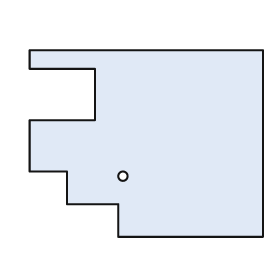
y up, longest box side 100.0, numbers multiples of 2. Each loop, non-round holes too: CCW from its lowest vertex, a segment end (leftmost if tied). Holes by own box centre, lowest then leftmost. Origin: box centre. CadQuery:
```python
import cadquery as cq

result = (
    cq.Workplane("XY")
    .moveTo(-12.0, -40.0)
    .lineTo(50.0, -40.0)
    .lineTo(50.0, 40.0)
    .lineTo(-50.0, 40.0)
    .lineTo(-50.0, 32.0)
    .lineTo(-22.0, 32.0)
    .lineTo(-22.0, 10.0)
    .lineTo(-50.0, 10.0)
    .lineTo(-50.0, -12.0)
    .lineTo(-34.0, -12.0)
    .lineTo(-34.0, -26.0)
    .lineTo(-12.0, -26.0)
    .close()
    .moveTo(-10.0, -14.0)
    .circle(2.0)
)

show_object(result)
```